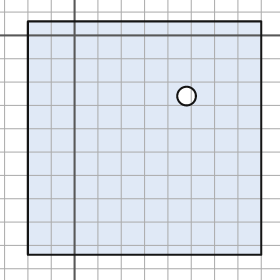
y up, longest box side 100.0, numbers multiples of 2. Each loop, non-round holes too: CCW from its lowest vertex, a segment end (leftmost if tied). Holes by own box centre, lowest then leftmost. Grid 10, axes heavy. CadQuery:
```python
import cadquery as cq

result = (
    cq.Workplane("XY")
    .moveTo(-20.0, -94.0)
    .lineTo(80.0, -94.0)
    .lineTo(80.0, 6.0)
    .lineTo(-20.0, 6.0)
    .close()
    .moveTo(48.0, -26.0)
    .circle(4.0)
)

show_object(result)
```